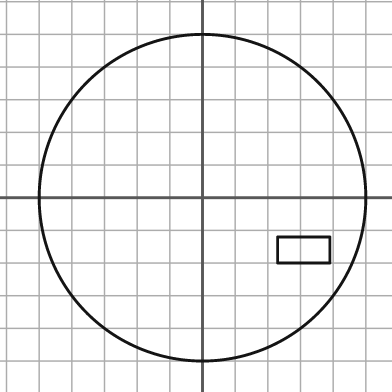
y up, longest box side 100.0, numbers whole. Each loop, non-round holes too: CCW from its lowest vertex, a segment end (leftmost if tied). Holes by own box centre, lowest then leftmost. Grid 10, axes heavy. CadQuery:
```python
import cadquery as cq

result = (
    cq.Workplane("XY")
    .moveTo(0.0, 0.0)
    .circle(50.0)
    .moveTo(23.0, -20.0)
    .lineTo(39.0, -20.0)
    .lineTo(39.0, -12.0)
    .lineTo(23.0, -12.0)
    .close()
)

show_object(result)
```